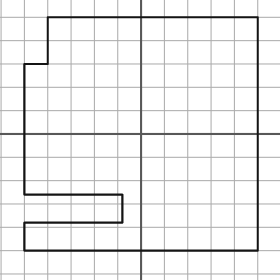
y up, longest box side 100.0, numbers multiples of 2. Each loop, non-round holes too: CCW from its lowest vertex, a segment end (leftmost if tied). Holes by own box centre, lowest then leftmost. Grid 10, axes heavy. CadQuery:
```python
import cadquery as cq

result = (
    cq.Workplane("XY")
    .moveTo(-50.0, -50.0)
    .lineTo(50.0, -50.0)
    .lineTo(50.0, 50.0)
    .lineTo(-40.0, 50.0)
    .lineTo(-40.0, 30.0)
    .lineTo(-50.0, 30.0)
    .lineTo(-50.0, -26.0)
    .lineTo(-8.0, -26.0)
    .lineTo(-8.0, -38.0)
    .lineTo(-50.0, -38.0)
    .close()
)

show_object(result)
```